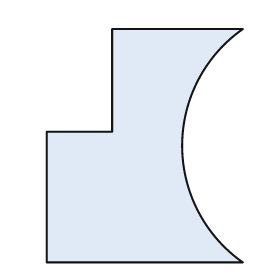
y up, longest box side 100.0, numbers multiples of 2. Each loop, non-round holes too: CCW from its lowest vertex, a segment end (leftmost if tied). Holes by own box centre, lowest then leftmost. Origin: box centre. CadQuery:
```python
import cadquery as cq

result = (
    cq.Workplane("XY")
    .moveTo(-42.0, -50.0)
    .lineTo(42.0, -50.0)
    .threePointArc((16.0, 0.0), (42.0, 50.0))
    .lineTo(-14.0, 50.0)
    .lineTo(-14.0, 6.0)
    .lineTo(-42.0, 6.0)
    .close()
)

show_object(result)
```